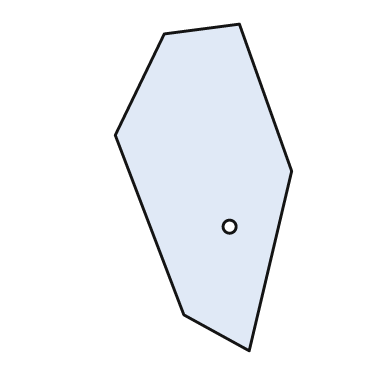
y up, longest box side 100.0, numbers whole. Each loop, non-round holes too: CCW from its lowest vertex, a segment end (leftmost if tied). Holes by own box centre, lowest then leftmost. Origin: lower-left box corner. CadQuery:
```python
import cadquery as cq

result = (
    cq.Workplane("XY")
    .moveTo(41.0, 0.0)
    .lineTo(54.0, 55.0)
    .lineTo(38.0, 100.0)
    .lineTo(15.0, 97.0)
    .lineTo(0.0, 66.0)
    .lineTo(21.0, 11.0)
    .close()
    .moveTo(35.0, 38.0)
    .circle(2.0)
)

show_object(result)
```